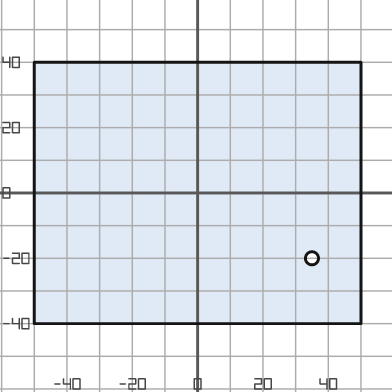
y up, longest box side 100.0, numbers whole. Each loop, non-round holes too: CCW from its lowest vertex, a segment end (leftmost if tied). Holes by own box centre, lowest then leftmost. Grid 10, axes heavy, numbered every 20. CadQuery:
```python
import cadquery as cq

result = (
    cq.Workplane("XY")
    .moveTo(-50.0, -40.0)
    .lineTo(50.0, -40.0)
    .lineTo(50.0, 40.0)
    .lineTo(-50.0, 40.0)
    .close()
    .moveTo(35.0, -20.0)
    .circle(2.0)
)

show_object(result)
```